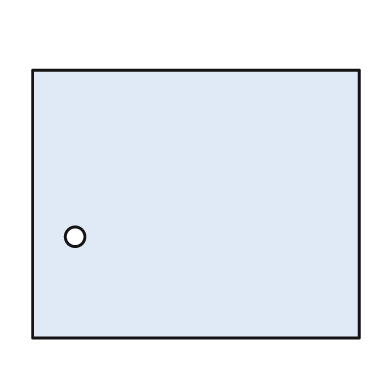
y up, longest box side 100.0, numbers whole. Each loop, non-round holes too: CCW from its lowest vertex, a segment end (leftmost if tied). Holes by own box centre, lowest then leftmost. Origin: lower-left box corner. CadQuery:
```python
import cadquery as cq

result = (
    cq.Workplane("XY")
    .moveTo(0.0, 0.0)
    .lineTo(100.0, 0.0)
    .lineTo(100.0, 82.0)
    .lineTo(0.0, 82.0)
    .close()
    .moveTo(13.0, 31.0)
    .circle(3.0)
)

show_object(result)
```